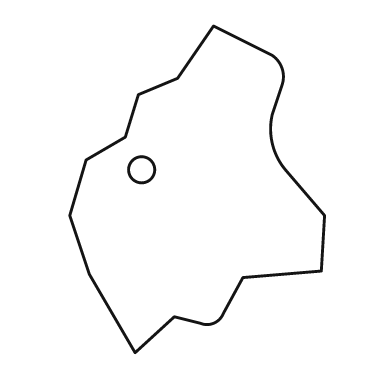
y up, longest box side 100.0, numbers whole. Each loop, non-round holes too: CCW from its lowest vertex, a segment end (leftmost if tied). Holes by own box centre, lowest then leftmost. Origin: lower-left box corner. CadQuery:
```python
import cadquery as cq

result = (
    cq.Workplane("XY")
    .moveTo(20.0, 0.0)
    .lineTo(32.0, 11.0)
    .lineTo(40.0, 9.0)
    .threePointArc((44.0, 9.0), (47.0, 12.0))
    .lineTo(53.0, 23.0)
    .lineTo(77.0, 25.0)
    .lineTo(78.0, 42.0)
    .lineTo(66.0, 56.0)
    .threePointArc((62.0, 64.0), (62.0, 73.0))
    .lineTo(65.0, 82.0)
    .threePointArc((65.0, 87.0), (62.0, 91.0))
    .lineTo(44.0, 100.0)
    .lineTo(33.0, 84.0)
    .lineTo(21.0, 79.0)
    .lineTo(17.0, 66.0)
    .lineTo(5.0, 59.0)
    .lineTo(0.0, 42.0)
    .lineTo(6.0, 24.0)
    .close()
    .moveTo(22.0, 56.0)
    .circle(4.0)
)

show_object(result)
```